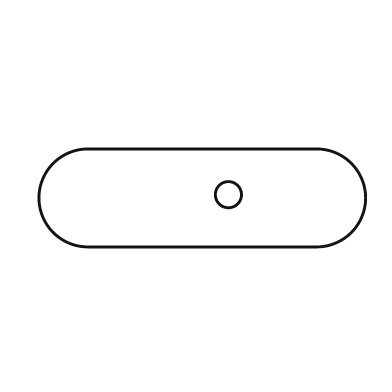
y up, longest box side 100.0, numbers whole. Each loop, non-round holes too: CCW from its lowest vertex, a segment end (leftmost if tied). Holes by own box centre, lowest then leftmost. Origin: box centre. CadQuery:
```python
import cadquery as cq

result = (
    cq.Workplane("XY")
    .moveTo(-35.0, -15.0)
    .lineTo(35.0, -15.0)
    .threePointArc((50.0, 0.0), (35.0, 15.0))
    .lineTo(-35.0, 15.0)
    .threePointArc((-50.0, 0.0), (-35.0, -15.0))
    .close()
    .moveTo(8.0, 1.0)
    .circle(4.0)
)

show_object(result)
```